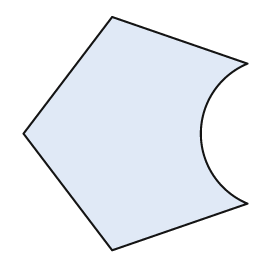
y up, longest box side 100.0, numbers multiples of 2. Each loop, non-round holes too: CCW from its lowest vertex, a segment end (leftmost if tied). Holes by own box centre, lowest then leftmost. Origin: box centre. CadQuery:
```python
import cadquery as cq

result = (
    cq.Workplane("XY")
    .moveTo(-10.0, -50.0)
    .lineTo(48.0, -30.0)
    .threePointArc((28.0, 0.0), (48.0, 30.0))
    .lineTo(-10.0, 50.0)
    .lineTo(-48.0, 0.0)
    .close()
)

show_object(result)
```